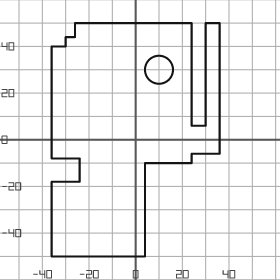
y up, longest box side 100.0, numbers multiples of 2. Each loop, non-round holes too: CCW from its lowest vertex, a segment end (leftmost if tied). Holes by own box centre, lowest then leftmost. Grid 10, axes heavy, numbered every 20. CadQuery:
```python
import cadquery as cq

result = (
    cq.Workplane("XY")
    .moveTo(-36.0, -50.0)
    .lineTo(4.0, -50.0)
    .lineTo(4.0, -10.0)
    .lineTo(24.0, -10.0)
    .lineTo(24.0, -6.0)
    .lineTo(36.0, -6.0)
    .lineTo(36.0, 50.0)
    .lineTo(30.0, 50.0)
    .lineTo(30.0, 6.0)
    .lineTo(24.0, 6.0)
    .lineTo(24.0, 50.0)
    .lineTo(-26.0, 50.0)
    .lineTo(-26.0, 44.0)
    .lineTo(-30.0, 44.0)
    .lineTo(-30.0, 40.0)
    .lineTo(-36.0, 40.0)
    .lineTo(-36.0, -8.0)
    .lineTo(-24.0, -8.0)
    .lineTo(-24.0, -18.0)
    .lineTo(-36.0, -18.0)
    .close()
    .moveTo(10.0, 30.0)
    .circle(6.0)
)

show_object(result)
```